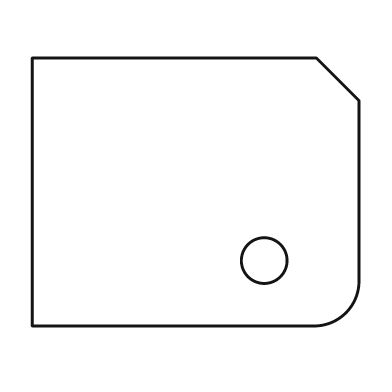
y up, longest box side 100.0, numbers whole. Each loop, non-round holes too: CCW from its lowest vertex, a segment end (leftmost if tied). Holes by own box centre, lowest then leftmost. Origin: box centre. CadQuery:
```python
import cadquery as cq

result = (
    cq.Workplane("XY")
    .moveTo(-50.0, -41.0)
    .lineTo(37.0, -41.0)
    .threePointArc((46.0, -37.0), (50.0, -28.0))
    .lineTo(50.0, 28.0)
    .lineTo(37.0, 41.0)
    .lineTo(-50.0, 41.0)
    .close()
    .moveTo(21.0, -21.0)
    .circle(7.0)
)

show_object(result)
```